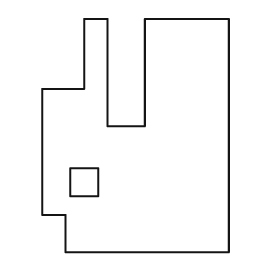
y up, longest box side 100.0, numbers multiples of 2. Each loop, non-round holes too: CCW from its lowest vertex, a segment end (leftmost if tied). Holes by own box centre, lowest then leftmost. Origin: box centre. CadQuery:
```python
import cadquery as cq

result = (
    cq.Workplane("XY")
    .moveTo(-30.0, -50.0)
    .lineTo(40.0, -50.0)
    .lineTo(40.0, 50.0)
    .lineTo(4.0, 50.0)
    .lineTo(4.0, 4.0)
    .lineTo(-12.0, 4.0)
    .lineTo(-12.0, 50.0)
    .lineTo(-22.0, 50.0)
    .lineTo(-22.0, 20.0)
    .lineTo(-40.0, 20.0)
    .lineTo(-40.0, -34.0)
    .lineTo(-30.0, -34.0)
    .close()
    .moveTo(-28.0, -26.0)
    .lineTo(-16.0, -26.0)
    .lineTo(-16.0, -14.0)
    .lineTo(-28.0, -14.0)
    .close()
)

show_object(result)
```